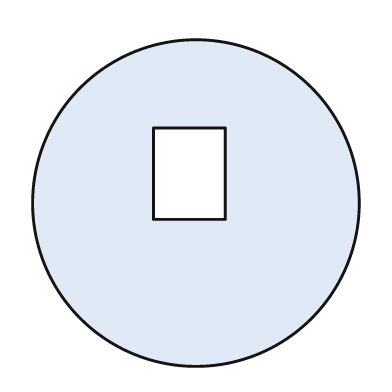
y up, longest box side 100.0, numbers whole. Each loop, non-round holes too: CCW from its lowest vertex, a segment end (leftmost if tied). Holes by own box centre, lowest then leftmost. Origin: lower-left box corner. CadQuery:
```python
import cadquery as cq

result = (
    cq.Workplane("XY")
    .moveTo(50.0, 50.0)
    .circle(50.0)
    .moveTo(37.0, 45.0)
    .lineTo(59.0, 45.0)
    .lineTo(59.0, 73.0)
    .lineTo(37.0, 73.0)
    .close()
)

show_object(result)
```